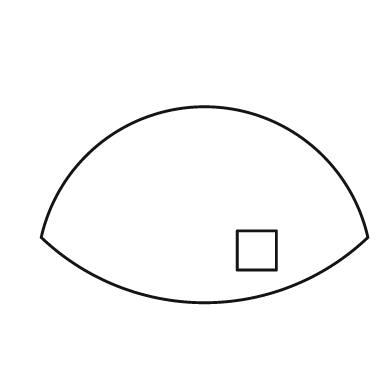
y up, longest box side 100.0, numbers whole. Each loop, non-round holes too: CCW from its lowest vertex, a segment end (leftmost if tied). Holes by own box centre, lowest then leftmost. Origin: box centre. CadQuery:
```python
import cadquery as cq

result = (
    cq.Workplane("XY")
    .moveTo(-50.0, -10.0)
    .threePointArc((0.0, -30.0), (50.0, -10.0))
    .threePointArc((0.0, 30.0), (-50.0, -10.0))
    .close()
    .moveTo(10.0, -20.0)
    .lineTo(22.0, -20.0)
    .lineTo(22.0, -8.0)
    .lineTo(10.0, -8.0)
    .close()
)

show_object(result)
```